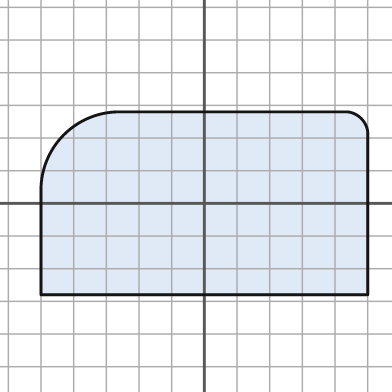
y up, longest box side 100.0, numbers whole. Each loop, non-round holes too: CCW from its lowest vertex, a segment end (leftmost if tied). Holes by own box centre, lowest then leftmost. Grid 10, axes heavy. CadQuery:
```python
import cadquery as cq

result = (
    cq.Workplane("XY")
    .moveTo(-50.0, -28.0)
    .lineTo(50.0, -28.0)
    .lineTo(50.0, 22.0)
    .threePointArc((48.0, 26.0), (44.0, 28.0))
    .lineTo(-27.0, 28.0)
    .threePointArc((-43.0, 21.0), (-50.0, 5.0))
    .close()
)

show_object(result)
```